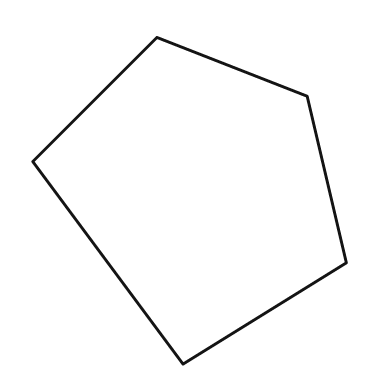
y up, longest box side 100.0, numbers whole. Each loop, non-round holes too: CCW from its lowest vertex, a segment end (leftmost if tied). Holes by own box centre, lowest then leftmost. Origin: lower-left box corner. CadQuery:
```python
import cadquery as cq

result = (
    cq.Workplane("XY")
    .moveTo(46.0, 0.0)
    .lineTo(96.0, 31.0)
    .lineTo(84.0, 82.0)
    .lineTo(38.0, 100.0)
    .lineTo(0.0, 62.0)
    .close()
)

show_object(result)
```